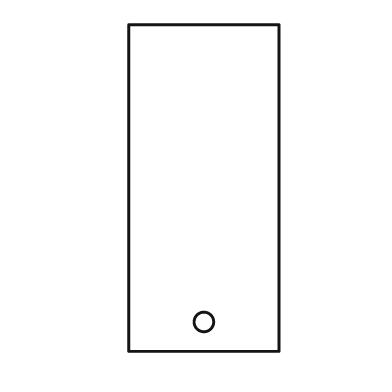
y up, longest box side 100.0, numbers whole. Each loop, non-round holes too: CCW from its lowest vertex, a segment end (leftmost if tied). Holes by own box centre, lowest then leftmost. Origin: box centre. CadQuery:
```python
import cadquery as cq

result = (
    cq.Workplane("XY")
    .moveTo(-23.0, -50.0)
    .lineTo(23.0, -50.0)
    .lineTo(23.0, 50.0)
    .lineTo(-23.0, 50.0)
    .close()
    .moveTo(0.0, -41.0)
    .circle(3.0)
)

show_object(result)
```